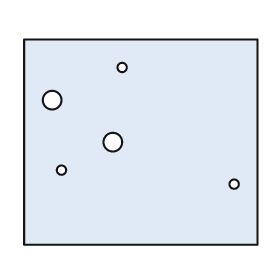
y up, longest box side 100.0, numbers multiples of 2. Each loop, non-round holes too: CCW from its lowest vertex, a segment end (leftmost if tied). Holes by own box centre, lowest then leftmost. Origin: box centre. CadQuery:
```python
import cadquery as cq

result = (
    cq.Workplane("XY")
    .moveTo(-50.0, -44.0)
    .lineTo(50.0, -44.0)
    .lineTo(50.0, 44.0)
    .lineTo(-50.0, 44.0)
    .close()
    .moveTo(40.0, -18.0)
    .circle(2.0)
    .moveTo(-34.0, -12.0)
    .circle(2.0)
    .moveTo(-12.0, 0.0)
    .circle(4.0)
    .moveTo(-38.0, 18.0)
    .circle(4.0)
    .moveTo(-8.0, 32.0)
    .circle(2.0)
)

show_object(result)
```